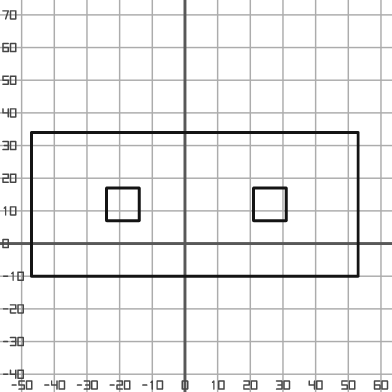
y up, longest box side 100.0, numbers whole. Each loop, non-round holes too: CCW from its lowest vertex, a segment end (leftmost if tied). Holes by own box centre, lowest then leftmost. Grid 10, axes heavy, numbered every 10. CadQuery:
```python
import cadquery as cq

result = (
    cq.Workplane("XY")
    .moveTo(-47.0, -10.0)
    .lineTo(53.0, -10.0)
    .lineTo(53.0, 34.0)
    .lineTo(-47.0, 34.0)
    .close()
    .moveTo(-24.0, 7.0)
    .lineTo(-14.0, 7.0)
    .lineTo(-14.0, 17.0)
    .lineTo(-24.0, 17.0)
    .close()
    .moveTo(21.0, 7.0)
    .lineTo(31.0, 7.0)
    .lineTo(31.0, 17.0)
    .lineTo(21.0, 17.0)
    .close()
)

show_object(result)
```